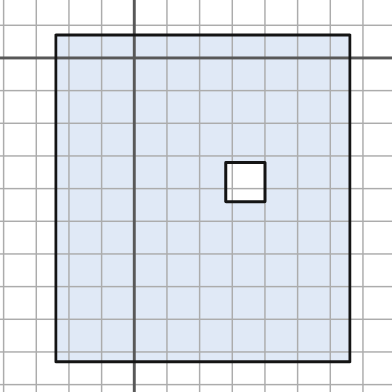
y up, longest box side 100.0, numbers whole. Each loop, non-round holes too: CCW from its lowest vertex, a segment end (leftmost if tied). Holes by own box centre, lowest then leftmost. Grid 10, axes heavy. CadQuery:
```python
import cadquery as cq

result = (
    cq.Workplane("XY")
    .moveTo(-24.0, -93.0)
    .lineTo(66.0, -93.0)
    .lineTo(66.0, 7.0)
    .lineTo(-24.0, 7.0)
    .close()
    .moveTo(28.0, -44.0)
    .lineTo(40.0, -44.0)
    .lineTo(40.0, -32.0)
    .lineTo(28.0, -32.0)
    .close()
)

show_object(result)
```